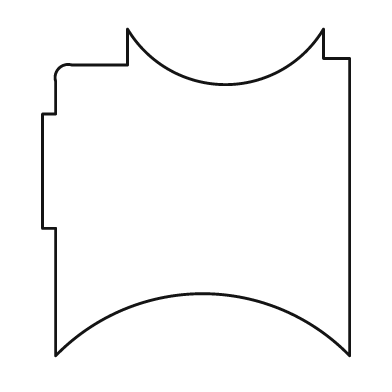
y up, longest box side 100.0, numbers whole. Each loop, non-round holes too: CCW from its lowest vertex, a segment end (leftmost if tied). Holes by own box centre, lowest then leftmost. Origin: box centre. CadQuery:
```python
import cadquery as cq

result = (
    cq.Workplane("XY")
    .moveTo(-43.0, -50.0)
    .threePointArc((2.0, -31.0), (47.0, -50.0))
    .lineTo(47.0, 41.0)
    .lineTo(39.0, 41.0)
    .lineTo(39.0, 50.0)
    .threePointArc((9.0, 33.0), (-21.0, 50.0))
    .lineTo(-21.0, 39.0)
    .lineTo(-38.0, 39.0)
    .threePointArc((-42.0, 38.0), (-43.0, 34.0))
    .lineTo(-43.0, 24.0)
    .lineTo(-47.0, 24.0)
    .lineTo(-47.0, -11.0)
    .lineTo(-43.0, -11.0)
    .close()
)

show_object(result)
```